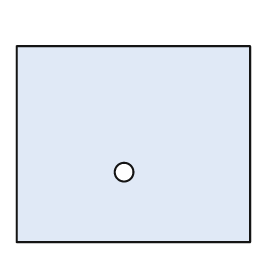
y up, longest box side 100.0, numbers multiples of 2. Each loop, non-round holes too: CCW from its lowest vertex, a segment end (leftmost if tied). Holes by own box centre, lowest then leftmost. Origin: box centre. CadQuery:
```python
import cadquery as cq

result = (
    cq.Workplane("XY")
    .moveTo(-50.0, -42.0)
    .lineTo(50.0, -42.0)
    .lineTo(50.0, 42.0)
    .lineTo(-50.0, 42.0)
    .close()
    .moveTo(-4.0, -12.0)
    .circle(4.0)
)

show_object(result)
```